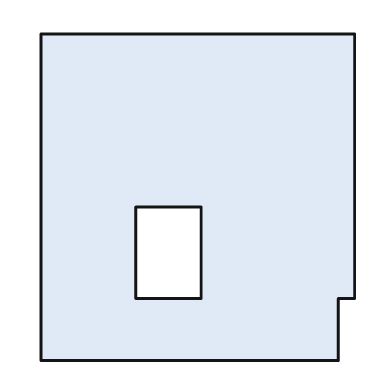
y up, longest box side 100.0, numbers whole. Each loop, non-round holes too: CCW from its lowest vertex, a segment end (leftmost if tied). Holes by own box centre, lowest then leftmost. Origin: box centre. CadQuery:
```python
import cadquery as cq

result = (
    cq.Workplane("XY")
    .moveTo(-48.0, -50.0)
    .lineTo(43.0, -50.0)
    .lineTo(43.0, -31.0)
    .lineTo(48.0, -31.0)
    .lineTo(48.0, 50.0)
    .lineTo(-48.0, 50.0)
    .close()
    .moveTo(-19.0, -31.0)
    .lineTo(1.0, -31.0)
    .lineTo(1.0, -3.0)
    .lineTo(-19.0, -3.0)
    .close()
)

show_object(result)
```